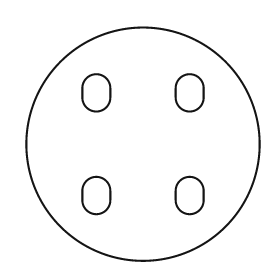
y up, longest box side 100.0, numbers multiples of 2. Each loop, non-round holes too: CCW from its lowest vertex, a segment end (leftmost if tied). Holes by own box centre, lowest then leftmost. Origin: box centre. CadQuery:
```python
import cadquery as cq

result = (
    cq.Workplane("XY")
    .moveTo(0.0, 0.0)
    .circle(50.0)
    .moveTo(-26.0, -24.0)
    .threePointArc((-20.0, -30.0), (-14.0, -24.0))
    .lineTo(-14.0, -20.0)
    .threePointArc((-20.0, -14.0), (-26.0, -20.0))
    .close()
    .moveTo(14.0, -24.0)
    .threePointArc((20.0, -30.0), (26.0, -24.0))
    .lineTo(26.0, -20.0)
    .threePointArc((20.0, -14.0), (14.0, -20.0))
    .close()
    .moveTo(-26.0, 20.0)
    .threePointArc((-20.0, 14.0), (-14.0, 20.0))
    .lineTo(-14.0, 24.0)
    .threePointArc((-20.0, 30.0), (-26.0, 24.0))
    .close()
    .moveTo(14.0, 20.0)
    .threePointArc((20.0, 14.0), (26.0, 20.0))
    .lineTo(26.0, 24.0)
    .threePointArc((20.0, 30.0), (14.0, 24.0))
    .close()
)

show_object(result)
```